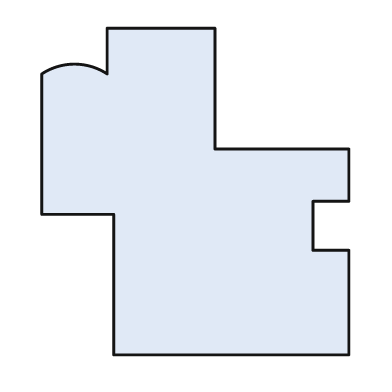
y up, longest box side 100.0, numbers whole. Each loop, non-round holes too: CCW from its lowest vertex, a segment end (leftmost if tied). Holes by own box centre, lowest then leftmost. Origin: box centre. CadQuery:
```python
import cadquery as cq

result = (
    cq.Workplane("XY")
    .moveTo(-25.0, -50.0)
    .lineTo(47.0, -50.0)
    .lineTo(47.0, -18.0)
    .lineTo(36.0, -18.0)
    .lineTo(36.0, -3.0)
    .lineTo(47.0, -3.0)
    .lineTo(47.0, 13.0)
    .lineTo(6.0, 13.0)
    .lineTo(6.0, 50.0)
    .lineTo(-27.0, 50.0)
    .lineTo(-27.0, 36.0)
    .threePointArc((-37.0, 39.0), (-47.0, 36.0))
    .lineTo(-47.0, -7.0)
    .lineTo(-25.0, -7.0)
    .close()
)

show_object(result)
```